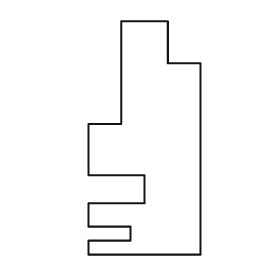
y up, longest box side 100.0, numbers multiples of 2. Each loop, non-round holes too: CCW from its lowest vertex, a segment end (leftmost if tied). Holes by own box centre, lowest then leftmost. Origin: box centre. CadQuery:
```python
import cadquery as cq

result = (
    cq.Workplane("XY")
    .moveTo(-24.0, -50.0)
    .lineTo(24.0, -50.0)
    .lineTo(24.0, 32.0)
    .lineTo(10.0, 32.0)
    .lineTo(10.0, 50.0)
    .lineTo(-10.0, 50.0)
    .lineTo(-10.0, 6.0)
    .lineTo(-24.0, 6.0)
    .lineTo(-24.0, -16.0)
    .lineTo(0.0, -16.0)
    .lineTo(0.0, -28.0)
    .lineTo(-24.0, -28.0)
    .lineTo(-24.0, -38.0)
    .lineTo(-6.0, -38.0)
    .lineTo(-6.0, -44.0)
    .lineTo(-24.0, -44.0)
    .close()
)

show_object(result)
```